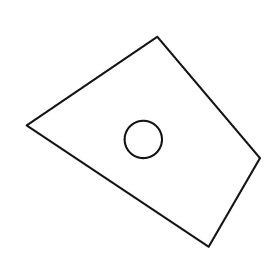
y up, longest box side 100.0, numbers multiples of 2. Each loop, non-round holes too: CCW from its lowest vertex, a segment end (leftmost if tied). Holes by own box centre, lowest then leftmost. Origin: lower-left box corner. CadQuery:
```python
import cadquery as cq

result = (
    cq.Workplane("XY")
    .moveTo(78.0, 0.0)
    .lineTo(100.0, 38.0)
    .lineTo(56.0, 90.0)
    .lineTo(0.0, 52.0)
    .close()
    .moveTo(50.0, 46.0)
    .circle(8.0)
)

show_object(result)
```